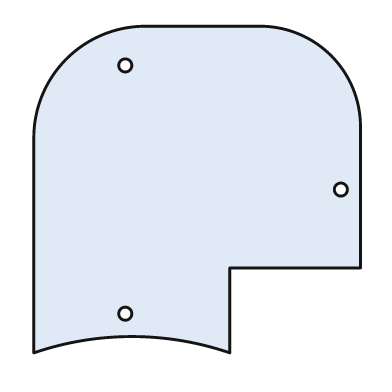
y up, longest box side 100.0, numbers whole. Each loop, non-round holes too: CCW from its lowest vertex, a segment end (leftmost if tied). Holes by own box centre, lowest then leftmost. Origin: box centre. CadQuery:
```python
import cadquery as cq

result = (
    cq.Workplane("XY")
    .moveTo(-50.0, -50.0)
    .threePointArc((-20.0, -45.0), (10.0, -50.0))
    .lineTo(10.0, -24.0)
    .lineTo(50.0, -24.0)
    .lineTo(50.0, 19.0)
    .threePointArc((41.0, 41.0), (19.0, 50.0))
    .lineTo(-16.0, 50.0)
    .threePointArc((-40.0, 40.0), (-50.0, 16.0))
    .close()
    .moveTo(-22.0, -38.0)
    .circle(2.0)
    .moveTo(44.0, 0.0)
    .circle(2.0)
    .moveTo(-22.0, 38.0)
    .circle(2.0)
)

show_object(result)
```